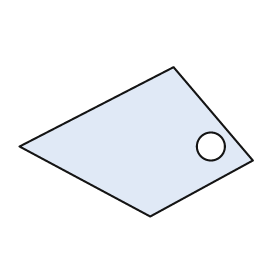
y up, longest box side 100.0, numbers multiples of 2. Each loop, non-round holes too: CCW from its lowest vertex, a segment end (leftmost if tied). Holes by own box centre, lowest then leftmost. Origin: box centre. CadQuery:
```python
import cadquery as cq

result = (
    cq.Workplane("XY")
    .moveTo(6.0, -32.0)
    .lineTo(50.0, -8.0)
    .lineTo(16.0, 32.0)
    .lineTo(-50.0, -2.0)
    .close()
    .moveTo(32.0, -2.0)
    .circle(6.0)
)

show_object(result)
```